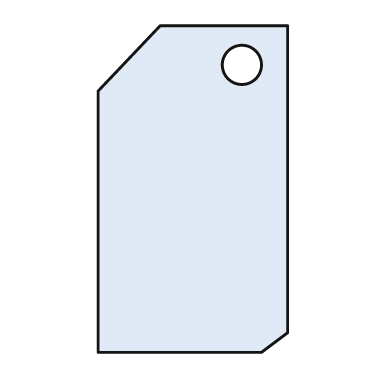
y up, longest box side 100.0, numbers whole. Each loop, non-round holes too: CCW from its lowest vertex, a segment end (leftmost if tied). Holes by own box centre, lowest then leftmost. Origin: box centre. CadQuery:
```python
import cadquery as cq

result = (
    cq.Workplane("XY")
    .moveTo(-29.0, -50.0)
    .lineTo(21.0, -50.0)
    .lineTo(29.0, -44.0)
    .lineTo(29.0, 50.0)
    .lineTo(-10.0, 50.0)
    .lineTo(-29.0, 30.0)
    .close()
    .moveTo(15.0, 38.0)
    .circle(6.0)
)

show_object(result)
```